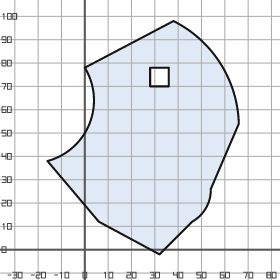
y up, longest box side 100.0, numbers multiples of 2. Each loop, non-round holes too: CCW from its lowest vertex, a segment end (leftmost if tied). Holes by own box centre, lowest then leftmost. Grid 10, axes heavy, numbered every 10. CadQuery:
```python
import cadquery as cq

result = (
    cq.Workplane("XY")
    .moveTo(32.0, -2.0)
    .lineTo(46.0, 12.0)
    .threePointArc((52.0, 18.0), (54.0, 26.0))
    .lineTo(66.0, 54.0)
    .threePointArc((58.0, 80.0), (38.0, 98.0))
    .lineTo(0.0, 78.0)
    .threePointArc((2.0, 54.0), (-16.0, 38.0))
    .lineTo(6.0, 12.0)
    .close()
    .moveTo(28.0, 70.0)
    .lineTo(36.0, 70.0)
    .lineTo(36.0, 78.0)
    .lineTo(28.0, 78.0)
    .close()
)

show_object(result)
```